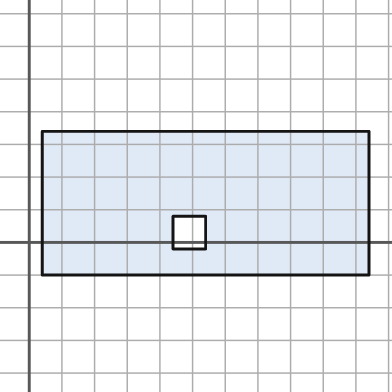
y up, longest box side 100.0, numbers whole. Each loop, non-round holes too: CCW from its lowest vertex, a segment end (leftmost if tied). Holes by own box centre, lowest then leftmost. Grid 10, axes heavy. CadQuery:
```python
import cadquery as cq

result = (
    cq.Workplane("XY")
    .moveTo(4.0, -10.0)
    .lineTo(104.0, -10.0)
    .lineTo(104.0, 34.0)
    .lineTo(4.0, 34.0)
    .close()
    .moveTo(44.0, -2.0)
    .lineTo(54.0, -2.0)
    .lineTo(54.0, 8.0)
    .lineTo(44.0, 8.0)
    .close()
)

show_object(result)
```